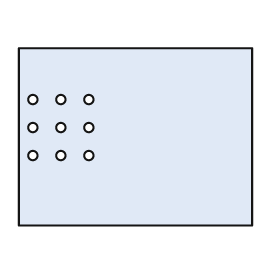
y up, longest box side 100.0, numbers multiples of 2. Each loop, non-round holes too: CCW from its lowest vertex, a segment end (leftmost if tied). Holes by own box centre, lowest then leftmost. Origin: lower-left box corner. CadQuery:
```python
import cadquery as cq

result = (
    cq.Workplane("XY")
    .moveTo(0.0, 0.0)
    .lineTo(100.0, 0.0)
    .lineTo(100.0, 76.0)
    .lineTo(0.0, 76.0)
    .close()
    .moveTo(6.0, 30.0)
    .circle(2.0)
    .moveTo(18.0, 30.0)
    .circle(2.0)
    .moveTo(30.0, 30.0)
    .circle(2.0)
    .moveTo(6.0, 42.0)
    .circle(2.0)
    .moveTo(18.0, 42.0)
    .circle(2.0)
    .moveTo(30.0, 42.0)
    .circle(2.0)
    .moveTo(6.0, 54.0)
    .circle(2.0)
    .moveTo(18.0, 54.0)
    .circle(2.0)
    .moveTo(30.0, 54.0)
    .circle(2.0)
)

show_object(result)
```